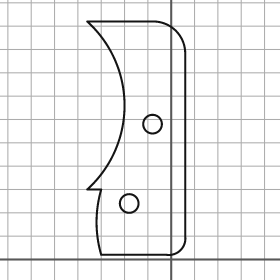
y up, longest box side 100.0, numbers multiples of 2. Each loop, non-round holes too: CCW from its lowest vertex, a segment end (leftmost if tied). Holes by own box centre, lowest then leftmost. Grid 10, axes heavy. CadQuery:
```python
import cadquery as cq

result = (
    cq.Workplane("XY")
    .moveTo(-30.0, 2.0)
    .lineTo(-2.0, 2.0)
    .threePointArc((4.0, 4.0), (6.0, 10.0))
    .lineTo(6.0, 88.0)
    .threePointArc((2.0, 98.0), (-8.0, 102.0))
    .lineTo(-36.0, 102.0)
    .threePointArc((-20.0, 66.0), (-36.0, 30.0))
    .lineTo(-30.0, 30.0)
    .threePointArc((-32.0, 16.0), (-30.0, 2.0))
    .close()
    .moveTo(-18.0, 24.0)
    .circle(4.0)
    .moveTo(-8.0, 58.0)
    .circle(4.0)
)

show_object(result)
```